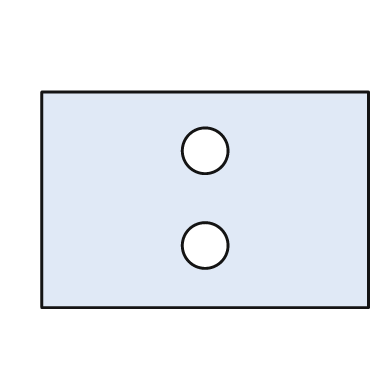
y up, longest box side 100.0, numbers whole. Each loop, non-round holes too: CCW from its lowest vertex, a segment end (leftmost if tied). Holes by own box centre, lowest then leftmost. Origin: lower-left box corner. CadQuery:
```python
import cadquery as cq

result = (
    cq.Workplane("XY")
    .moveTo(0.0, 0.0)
    .lineTo(100.0, 0.0)
    .lineTo(100.0, 66.0)
    .lineTo(0.0, 66.0)
    .close()
    .moveTo(50.0, 19.0)
    .circle(7.0)
    .moveTo(50.0, 48.0)
    .circle(7.0)
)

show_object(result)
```